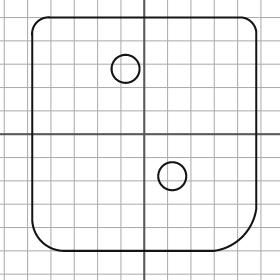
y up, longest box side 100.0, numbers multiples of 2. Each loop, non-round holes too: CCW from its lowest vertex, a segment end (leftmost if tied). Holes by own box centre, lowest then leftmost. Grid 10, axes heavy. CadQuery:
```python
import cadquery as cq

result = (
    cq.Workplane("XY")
    .moveTo(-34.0, -50.0)
    .lineTo(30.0, -50.0)
    .threePointArc((42.0, -44.0), (48.0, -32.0))
    .lineTo(48.0, 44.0)
    .threePointArc((46.0, 48.0), (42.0, 50.0))
    .lineTo(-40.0, 50.0)
    .threePointArc((-46.0, 48.0), (-48.0, 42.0))
    .lineTo(-48.0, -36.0)
    .threePointArc((-44.0, -46.0), (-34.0, -50.0))
    .close()
    .moveTo(12.0, -18.0)
    .circle(6.0)
    .moveTo(-8.0, 28.0)
    .circle(6.0)
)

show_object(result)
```